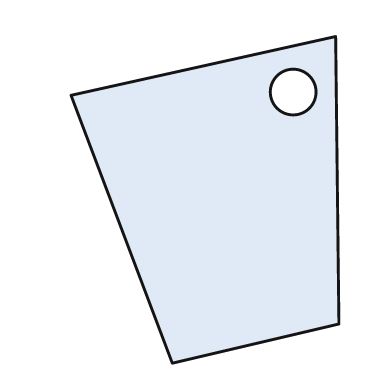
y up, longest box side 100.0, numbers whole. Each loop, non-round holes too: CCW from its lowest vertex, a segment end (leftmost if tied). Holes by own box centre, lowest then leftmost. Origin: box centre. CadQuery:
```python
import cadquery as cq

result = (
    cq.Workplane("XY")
    .moveTo(-10.0, -50.0)
    .lineTo(41.0, -38.0)
    .lineTo(40.0, 50.0)
    .lineTo(-41.0, 32.0)
    .close()
    .moveTo(27.0, 33.0)
    .circle(7.0)
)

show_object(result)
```